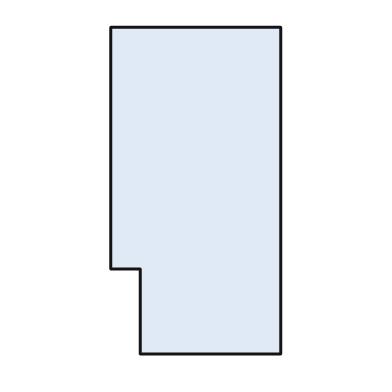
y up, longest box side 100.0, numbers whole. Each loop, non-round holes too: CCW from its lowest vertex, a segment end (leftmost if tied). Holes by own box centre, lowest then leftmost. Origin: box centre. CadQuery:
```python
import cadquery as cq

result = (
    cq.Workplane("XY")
    .moveTo(-17.0, -50.0)
    .lineTo(26.0, -50.0)
    .lineTo(26.0, 50.0)
    .lineTo(-26.0, 50.0)
    .lineTo(-26.0, -24.0)
    .lineTo(-17.0, -24.0)
    .close()
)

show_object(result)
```